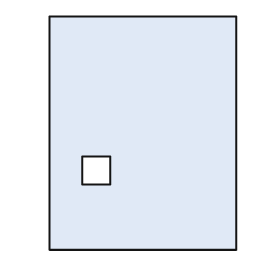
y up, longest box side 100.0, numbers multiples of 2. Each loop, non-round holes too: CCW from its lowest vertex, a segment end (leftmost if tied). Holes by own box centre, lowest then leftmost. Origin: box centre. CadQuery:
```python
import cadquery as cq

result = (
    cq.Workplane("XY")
    .moveTo(-40.0, -50.0)
    .lineTo(40.0, -50.0)
    .lineTo(40.0, 50.0)
    .lineTo(-40.0, 50.0)
    .close()
    .moveTo(-26.0, -22.0)
    .lineTo(-14.0, -22.0)
    .lineTo(-14.0, -10.0)
    .lineTo(-26.0, -10.0)
    .close()
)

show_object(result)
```